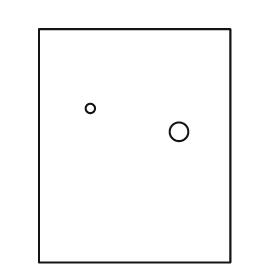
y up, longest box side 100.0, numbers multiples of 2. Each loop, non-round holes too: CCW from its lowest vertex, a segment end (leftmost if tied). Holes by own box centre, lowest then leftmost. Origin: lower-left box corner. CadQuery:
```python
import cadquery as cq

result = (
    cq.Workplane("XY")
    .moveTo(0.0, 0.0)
    .lineTo(82.0, 0.0)
    .lineTo(82.0, 100.0)
    .lineTo(0.0, 100.0)
    .close()
    .moveTo(60.0, 56.0)
    .circle(4.0)
    .moveTo(22.0, 66.0)
    .circle(2.0)
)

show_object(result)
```